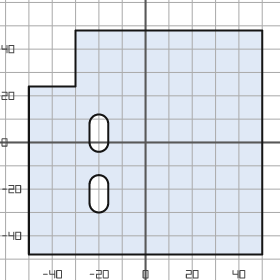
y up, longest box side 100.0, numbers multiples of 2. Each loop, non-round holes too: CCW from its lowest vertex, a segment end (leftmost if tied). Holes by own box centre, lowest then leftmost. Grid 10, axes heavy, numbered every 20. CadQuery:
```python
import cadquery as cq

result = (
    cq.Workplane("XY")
    .moveTo(-50.0, -48.0)
    .lineTo(50.0, -48.0)
    .lineTo(50.0, 48.0)
    .lineTo(-30.0, 48.0)
    .lineTo(-30.0, 24.0)
    .lineTo(-50.0, 24.0)
    .close()
    .moveTo(-24.0, -26.0)
    .threePointArc((-20.0, -30.0), (-16.0, -26.0))
    .lineTo(-16.0, -18.0)
    .threePointArc((-20.0, -14.0), (-24.0, -18.0))
    .close()
    .moveTo(-24.0, 0.0)
    .threePointArc((-20.0, -4.0), (-16.0, 0.0))
    .lineTo(-16.0, 8.0)
    .threePointArc((-20.0, 12.0), (-24.0, 8.0))
    .close()
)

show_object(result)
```